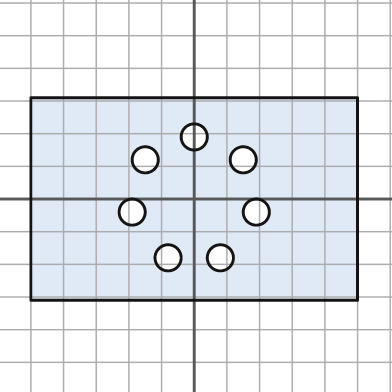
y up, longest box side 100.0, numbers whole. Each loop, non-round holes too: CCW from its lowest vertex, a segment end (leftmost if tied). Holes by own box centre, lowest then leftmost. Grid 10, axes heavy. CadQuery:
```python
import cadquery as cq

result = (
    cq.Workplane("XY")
    .moveTo(-50.0, -31.0)
    .lineTo(50.0, -31.0)
    .lineTo(50.0, 31.0)
    .lineTo(-50.0, 31.0)
    .close()
    .moveTo(-8.0, -18.0)
    .circle(4.0)
    .moveTo(8.0, -18.0)
    .circle(4.0)
    .moveTo(-19.0, -4.0)
    .circle(4.0)
    .moveTo(19.0, -4.0)
    .circle(4.0)
    .moveTo(-15.0, 12.0)
    .circle(4.0)
    .moveTo(15.0, 12.0)
    .circle(4.0)
    .moveTo(0.0, 19.0)
    .circle(4.0)
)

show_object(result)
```